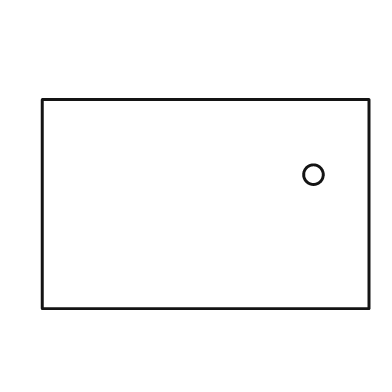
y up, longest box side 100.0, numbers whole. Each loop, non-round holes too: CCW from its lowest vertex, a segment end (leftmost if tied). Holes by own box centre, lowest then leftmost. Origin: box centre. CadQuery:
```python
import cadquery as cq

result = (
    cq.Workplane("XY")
    .moveTo(-50.0, -32.0)
    .lineTo(50.0, -32.0)
    .lineTo(50.0, 32.0)
    .lineTo(-50.0, 32.0)
    .close()
    .moveTo(33.0, 9.0)
    .circle(3.0)
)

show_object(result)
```